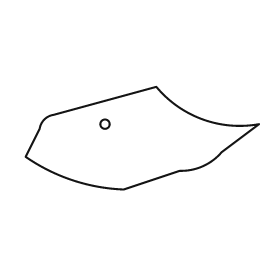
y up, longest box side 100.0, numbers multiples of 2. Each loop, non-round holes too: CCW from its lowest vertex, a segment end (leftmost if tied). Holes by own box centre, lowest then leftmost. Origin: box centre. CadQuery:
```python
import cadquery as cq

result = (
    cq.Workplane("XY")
    .moveTo(-8.0, -22.0)
    .lineTo(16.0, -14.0)
    .threePointArc((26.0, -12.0), (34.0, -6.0))
    .lineTo(50.0, 6.0)
    .threePointArc((26.0, 8.0), (6.0, 22.0))
    .lineTo(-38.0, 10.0)
    .threePointArc((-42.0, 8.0), (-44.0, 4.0))
    .lineTo(-50.0, -8.0)
    .threePointArc((-30.0, -18.0), (-8.0, -22.0))
    .close()
    .moveTo(-16.0, 6.0)
    .circle(2.0)
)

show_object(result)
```